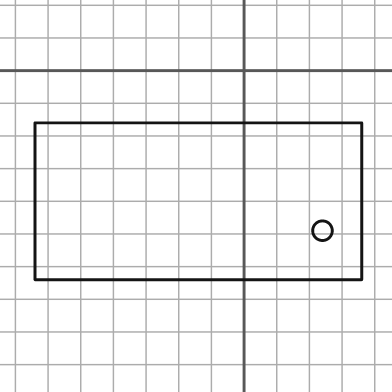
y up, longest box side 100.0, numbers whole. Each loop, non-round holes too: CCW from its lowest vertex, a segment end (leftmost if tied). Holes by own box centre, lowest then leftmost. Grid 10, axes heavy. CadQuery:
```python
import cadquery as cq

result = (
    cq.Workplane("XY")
    .moveTo(-64.0, -64.0)
    .lineTo(36.0, -64.0)
    .lineTo(36.0, -16.0)
    .lineTo(-64.0, -16.0)
    .close()
    .moveTo(24.0, -49.0)
    .circle(3.0)
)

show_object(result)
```